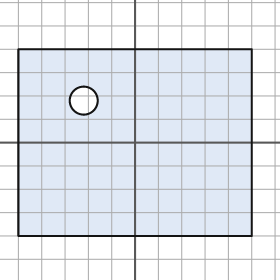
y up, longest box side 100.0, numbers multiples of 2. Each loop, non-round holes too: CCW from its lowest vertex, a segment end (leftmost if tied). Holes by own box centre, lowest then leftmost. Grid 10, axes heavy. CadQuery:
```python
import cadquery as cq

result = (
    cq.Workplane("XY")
    .moveTo(-50.0, -40.0)
    .lineTo(50.0, -40.0)
    .lineTo(50.0, 40.0)
    .lineTo(-50.0, 40.0)
    .close()
    .moveTo(-22.0, 18.0)
    .circle(6.0)
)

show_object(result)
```